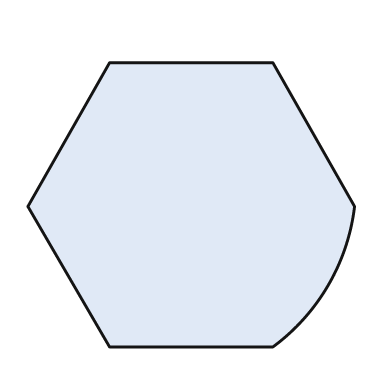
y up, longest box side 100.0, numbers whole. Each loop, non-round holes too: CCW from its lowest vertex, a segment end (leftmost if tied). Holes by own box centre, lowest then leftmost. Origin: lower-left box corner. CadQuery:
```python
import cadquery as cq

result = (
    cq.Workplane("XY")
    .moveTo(25.0, 0.0)
    .lineTo(75.0, 0.0)
    .threePointArc((92.0, 19.0), (100.0, 43.0))
    .lineTo(75.0, 87.0)
    .lineTo(25.0, 87.0)
    .lineTo(0.0, 43.0)
    .close()
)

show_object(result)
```